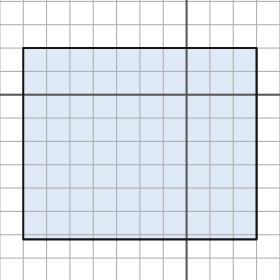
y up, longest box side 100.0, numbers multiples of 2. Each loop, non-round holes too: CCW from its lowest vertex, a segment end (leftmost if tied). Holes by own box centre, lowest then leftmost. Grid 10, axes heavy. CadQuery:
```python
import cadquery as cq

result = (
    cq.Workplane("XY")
    .moveTo(-70.0, -62.0)
    .lineTo(30.0, -62.0)
    .lineTo(30.0, 20.0)
    .lineTo(-70.0, 20.0)
    .close()
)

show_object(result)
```